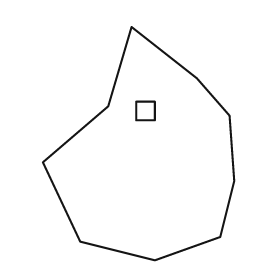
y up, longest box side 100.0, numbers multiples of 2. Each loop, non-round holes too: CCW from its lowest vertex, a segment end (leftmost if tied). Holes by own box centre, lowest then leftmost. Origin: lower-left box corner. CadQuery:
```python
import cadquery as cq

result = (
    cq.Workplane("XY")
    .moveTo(48.0, 0.0)
    .lineTo(76.0, 10.0)
    .lineTo(82.0, 34.0)
    .lineTo(80.0, 62.0)
    .lineTo(66.0, 78.0)
    .lineTo(38.0, 100.0)
    .lineTo(28.0, 66.0)
    .lineTo(0.0, 42.0)
    .lineTo(16.0, 8.0)
    .close()
    .moveTo(40.0, 60.0)
    .lineTo(48.0, 60.0)
    .lineTo(48.0, 68.0)
    .lineTo(40.0, 68.0)
    .close()
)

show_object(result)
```